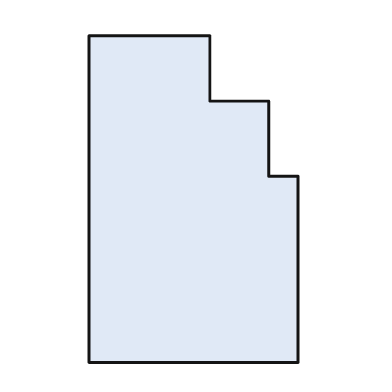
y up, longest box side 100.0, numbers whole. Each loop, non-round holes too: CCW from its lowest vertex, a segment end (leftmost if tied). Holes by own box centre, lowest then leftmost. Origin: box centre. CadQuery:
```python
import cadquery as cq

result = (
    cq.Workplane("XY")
    .moveTo(-32.0, -50.0)
    .lineTo(32.0, -50.0)
    .lineTo(32.0, 7.0)
    .lineTo(23.0, 7.0)
    .lineTo(23.0, 30.0)
    .lineTo(5.0, 30.0)
    .lineTo(5.0, 50.0)
    .lineTo(-32.0, 50.0)
    .close()
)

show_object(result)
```